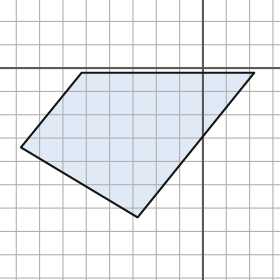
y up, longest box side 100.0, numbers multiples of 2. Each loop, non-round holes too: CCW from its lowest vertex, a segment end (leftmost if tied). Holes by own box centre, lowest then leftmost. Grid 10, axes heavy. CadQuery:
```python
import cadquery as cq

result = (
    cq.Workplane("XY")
    .moveTo(-28.0, -64.0)
    .lineTo(22.0, -2.0)
    .lineTo(-52.0, -2.0)
    .lineTo(-78.0, -34.0)
    .close()
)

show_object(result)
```